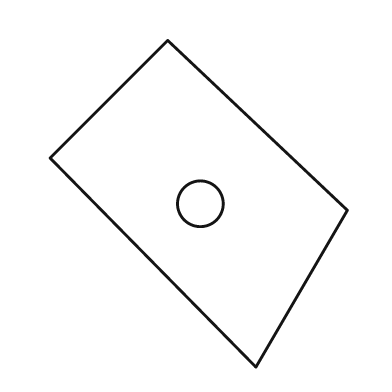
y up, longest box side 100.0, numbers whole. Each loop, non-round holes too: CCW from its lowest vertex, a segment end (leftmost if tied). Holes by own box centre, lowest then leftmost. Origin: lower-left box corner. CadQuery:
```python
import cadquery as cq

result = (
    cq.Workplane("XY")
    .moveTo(63.0, 0.0)
    .lineTo(91.0, 48.0)
    .lineTo(36.0, 100.0)
    .lineTo(0.0, 64.0)
    .close()
    .moveTo(46.0, 50.0)
    .circle(7.0)
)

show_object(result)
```